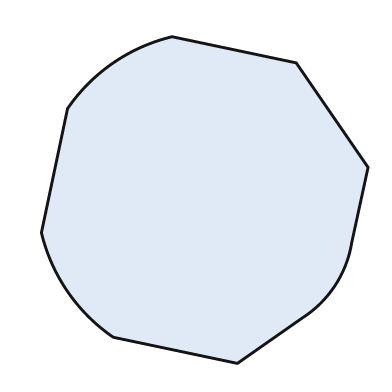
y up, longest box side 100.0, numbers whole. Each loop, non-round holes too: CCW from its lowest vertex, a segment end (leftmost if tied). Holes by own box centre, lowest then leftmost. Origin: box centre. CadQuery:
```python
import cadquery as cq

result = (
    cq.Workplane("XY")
    .moveTo(10.0, -50.0)
    .lineTo(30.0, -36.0)
    .threePointArc((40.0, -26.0), (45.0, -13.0))
    .lineTo(50.0, 10.0)
    .lineTo(28.0, 42.0)
    .lineTo(-10.0, 50.0)
    .threePointArc((-28.0, 42.0), (-42.0, 28.0))
    .lineTo(-50.0, -10.0)
    .threePointArc((-42.0, -28.0), (-28.0, -42.0))
    .close()
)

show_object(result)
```